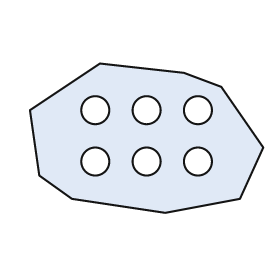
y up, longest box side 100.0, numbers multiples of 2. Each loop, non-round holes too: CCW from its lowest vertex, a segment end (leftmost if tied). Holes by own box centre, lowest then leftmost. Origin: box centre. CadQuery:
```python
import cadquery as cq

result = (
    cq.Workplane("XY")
    .moveTo(8.0, -32.0)
    .lineTo(40.0, -26.0)
    .lineTo(50.0, -4.0)
    .lineTo(32.0, 22.0)
    .lineTo(16.0, 28.0)
    .lineTo(-20.0, 32.0)
    .lineTo(-50.0, 12.0)
    .lineTo(-46.0, -16.0)
    .lineTo(-32.0, -26.0)
    .close()
    .moveTo(-22.0, -10.0)
    .circle(6.0)
    .moveTo(0.0, -10.0)
    .circle(6.0)
    .moveTo(22.0, -10.0)
    .circle(6.0)
    .moveTo(-22.0, 12.0)
    .circle(6.0)
    .moveTo(0.0, 12.0)
    .circle(6.0)
    .moveTo(22.0, 12.0)
    .circle(6.0)
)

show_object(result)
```